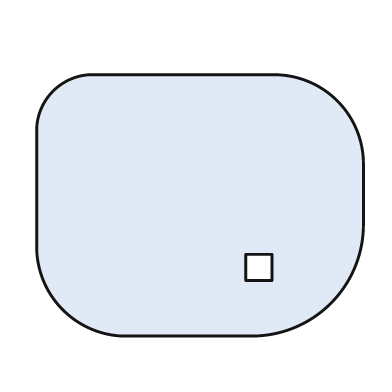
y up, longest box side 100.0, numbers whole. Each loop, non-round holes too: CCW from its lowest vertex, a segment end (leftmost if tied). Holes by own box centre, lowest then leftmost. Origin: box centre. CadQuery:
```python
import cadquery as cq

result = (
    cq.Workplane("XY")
    .moveTo(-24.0, -40.0)
    .lineTo(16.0, -40.0)
    .threePointArc((40.0, -30.0), (50.0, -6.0))
    .lineTo(50.0, 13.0)
    .threePointArc((42.0, 32.0), (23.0, 40.0))
    .lineTo(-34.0, 40.0)
    .threePointArc((-45.0, 35.0), (-50.0, 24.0))
    .lineTo(-50.0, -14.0)
    .threePointArc((-42.0, -32.0), (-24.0, -40.0))
    .close()
    .moveTo(14.0, -23.0)
    .lineTo(22.0, -23.0)
    .lineTo(22.0, -15.0)
    .lineTo(14.0, -15.0)
    .close()
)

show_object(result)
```